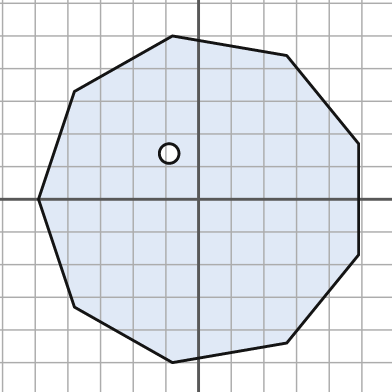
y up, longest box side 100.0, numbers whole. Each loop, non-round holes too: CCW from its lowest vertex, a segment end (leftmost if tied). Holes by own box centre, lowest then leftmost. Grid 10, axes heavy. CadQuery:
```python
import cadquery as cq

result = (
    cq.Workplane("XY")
    .moveTo(-8.0, -50.0)
    .lineTo(27.0, -44.0)
    .lineTo(49.0, -17.0)
    .lineTo(49.0, 17.0)
    .lineTo(27.0, 44.0)
    .lineTo(-8.0, 50.0)
    .lineTo(-38.0, 33.0)
    .lineTo(-49.0, 0.0)
    .lineTo(-38.0, -33.0)
    .close()
    .moveTo(-9.0, 14.0)
    .circle(3.0)
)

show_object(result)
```